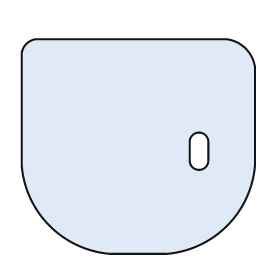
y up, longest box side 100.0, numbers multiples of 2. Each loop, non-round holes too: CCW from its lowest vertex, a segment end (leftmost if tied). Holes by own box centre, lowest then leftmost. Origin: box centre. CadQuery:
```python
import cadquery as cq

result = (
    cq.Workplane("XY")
    .moveTo(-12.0, -46.0)
    .lineTo(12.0, -46.0)
    .threePointArc((38.0, -34.0), (50.0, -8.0))
    .lineTo(50.0, 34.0)
    .threePointArc((46.0, 42.0), (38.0, 46.0))
    .lineTo(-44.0, 46.0)
    .threePointArc((-48.0, 44.0), (-50.0, 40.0))
    .lineTo(-50.0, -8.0)
    .threePointArc((-38.0, -34.0), (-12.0, -46.0))
    .close()
    .moveTo(22.0, -6.0)
    .threePointArc((26.0, -10.0), (30.0, -6.0))
    .lineTo(30.0, 2.0)
    .threePointArc((26.0, 6.0), (22.0, 2.0))
    .close()
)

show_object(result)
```